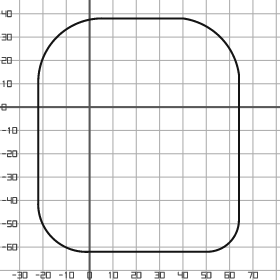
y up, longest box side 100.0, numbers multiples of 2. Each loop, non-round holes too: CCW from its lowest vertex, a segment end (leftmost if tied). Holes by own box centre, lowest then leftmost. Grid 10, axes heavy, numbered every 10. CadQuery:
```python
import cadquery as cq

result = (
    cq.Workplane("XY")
    .moveTo(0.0, -62.0)
    .lineTo(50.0, -62.0)
    .threePointArc((60.0, -58.0), (64.0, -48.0))
    .lineTo(64.0, 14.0)
    .threePointArc((56.0, 30.0), (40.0, 38.0))
    .lineTo(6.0, 38.0)
    .threePointArc((-14.0, 30.0), (-22.0, 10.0))
    .lineTo(-22.0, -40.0)
    .threePointArc((-16.0, -56.0), (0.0, -62.0))
    .close()
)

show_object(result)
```